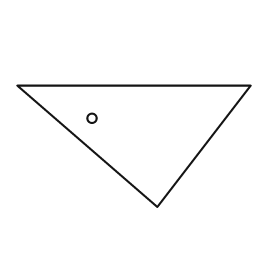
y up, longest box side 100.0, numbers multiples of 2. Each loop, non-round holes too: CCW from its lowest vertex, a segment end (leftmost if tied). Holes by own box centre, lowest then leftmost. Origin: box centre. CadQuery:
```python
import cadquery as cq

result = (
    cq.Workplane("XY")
    .moveTo(10.0, -26.0)
    .lineTo(50.0, 26.0)
    .lineTo(-50.0, 26.0)
    .close()
    .moveTo(-18.0, 12.0)
    .circle(2.0)
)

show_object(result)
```